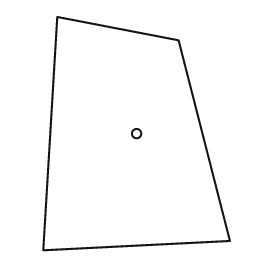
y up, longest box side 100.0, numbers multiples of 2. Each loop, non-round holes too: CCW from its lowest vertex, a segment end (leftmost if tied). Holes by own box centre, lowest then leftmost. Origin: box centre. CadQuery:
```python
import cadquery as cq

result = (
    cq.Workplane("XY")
    .moveTo(-40.0, -50.0)
    .lineTo(40.0, -46.0)
    .lineTo(18.0, 40.0)
    .lineTo(-34.0, 50.0)
    .close()
    .moveTo(0.0, 0.0)
    .circle(2.0)
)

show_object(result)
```